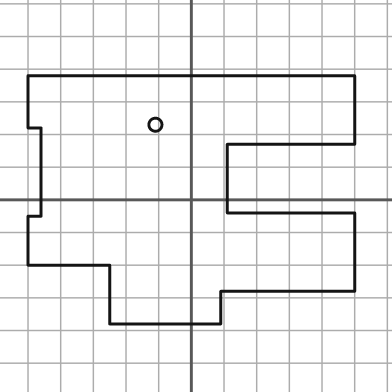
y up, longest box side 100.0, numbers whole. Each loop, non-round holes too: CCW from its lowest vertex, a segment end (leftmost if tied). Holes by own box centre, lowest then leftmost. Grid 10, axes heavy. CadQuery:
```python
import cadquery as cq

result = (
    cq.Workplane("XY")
    .moveTo(-25.0, -38.0)
    .lineTo(9.0, -38.0)
    .lineTo(9.0, -28.0)
    .lineTo(50.0, -28.0)
    .lineTo(50.0, -4.0)
    .lineTo(11.0, -4.0)
    .lineTo(11.0, 17.0)
    .lineTo(50.0, 17.0)
    .lineTo(50.0, 38.0)
    .lineTo(-50.0, 38.0)
    .lineTo(-50.0, 22.0)
    .lineTo(-46.0, 22.0)
    .lineTo(-46.0, -5.0)
    .lineTo(-50.0, -5.0)
    .lineTo(-50.0, -20.0)
    .lineTo(-25.0, -20.0)
    .close()
    .moveTo(-11.0, 23.0)
    .circle(2.0)
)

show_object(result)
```